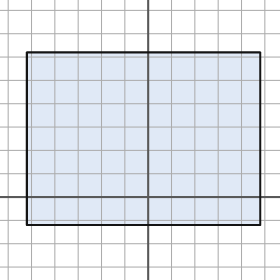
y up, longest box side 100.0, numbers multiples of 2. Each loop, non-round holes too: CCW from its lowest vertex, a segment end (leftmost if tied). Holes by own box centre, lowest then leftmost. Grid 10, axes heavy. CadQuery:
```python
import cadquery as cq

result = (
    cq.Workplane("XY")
    .moveTo(-52.0, -12.0)
    .lineTo(48.0, -12.0)
    .lineTo(48.0, 62.0)
    .lineTo(-52.0, 62.0)
    .close()
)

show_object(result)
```